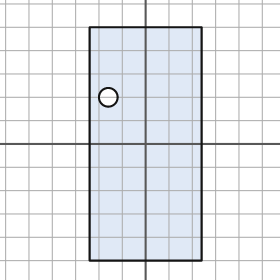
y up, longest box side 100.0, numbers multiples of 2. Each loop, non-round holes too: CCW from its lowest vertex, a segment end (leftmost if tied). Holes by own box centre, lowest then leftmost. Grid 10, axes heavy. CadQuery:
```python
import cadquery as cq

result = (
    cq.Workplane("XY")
    .moveTo(-24.0, -50.0)
    .lineTo(24.0, -50.0)
    .lineTo(24.0, 50.0)
    .lineTo(-24.0, 50.0)
    .close()
    .moveTo(-16.0, 20.0)
    .circle(4.0)
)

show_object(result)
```